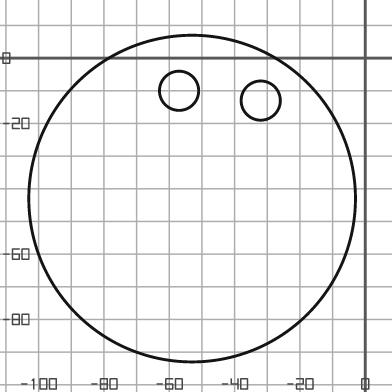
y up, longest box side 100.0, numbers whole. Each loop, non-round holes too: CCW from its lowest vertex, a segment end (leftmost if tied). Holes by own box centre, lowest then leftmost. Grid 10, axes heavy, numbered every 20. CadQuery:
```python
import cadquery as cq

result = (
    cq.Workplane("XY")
    .moveTo(-53.0, -43.0)
    .circle(50.0)
    .moveTo(-32.0, -13.0)
    .circle(6.0)
    .moveTo(-57.0, -10.0)
    .circle(6.0)
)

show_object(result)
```